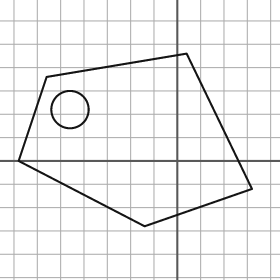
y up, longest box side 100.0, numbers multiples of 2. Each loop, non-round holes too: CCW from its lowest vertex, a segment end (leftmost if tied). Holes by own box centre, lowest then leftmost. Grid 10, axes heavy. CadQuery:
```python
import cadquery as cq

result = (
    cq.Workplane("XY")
    .moveTo(-14.0, -28.0)
    .lineTo(32.0, -12.0)
    .lineTo(4.0, 46.0)
    .lineTo(-56.0, 36.0)
    .lineTo(-68.0, 0.0)
    .close()
    .moveTo(-46.0, 22.0)
    .circle(8.0)
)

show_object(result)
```